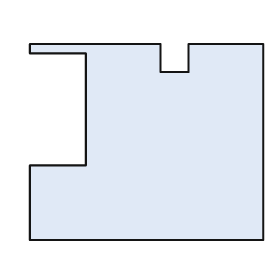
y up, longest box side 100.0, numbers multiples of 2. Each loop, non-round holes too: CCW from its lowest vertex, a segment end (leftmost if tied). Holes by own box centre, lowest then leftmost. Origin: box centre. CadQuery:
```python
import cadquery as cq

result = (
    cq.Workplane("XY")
    .moveTo(-50.0, -42.0)
    .lineTo(50.0, -42.0)
    .lineTo(50.0, 42.0)
    .lineTo(18.0, 42.0)
    .lineTo(18.0, 30.0)
    .lineTo(6.0, 30.0)
    .lineTo(6.0, 42.0)
    .lineTo(-50.0, 42.0)
    .lineTo(-50.0, 38.0)
    .lineTo(-26.0, 38.0)
    .lineTo(-26.0, -10.0)
    .lineTo(-50.0, -10.0)
    .close()
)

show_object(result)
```